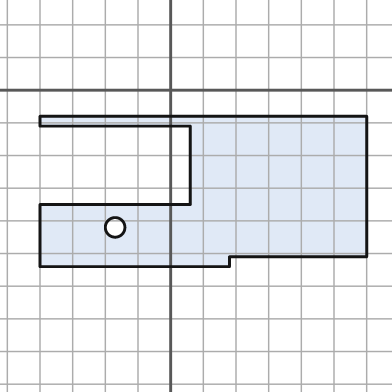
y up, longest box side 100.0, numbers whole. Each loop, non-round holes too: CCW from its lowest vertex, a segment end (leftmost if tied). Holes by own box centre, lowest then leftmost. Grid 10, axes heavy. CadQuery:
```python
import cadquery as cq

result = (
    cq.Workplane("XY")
    .moveTo(-40.0, -54.0)
    .lineTo(18.0, -54.0)
    .lineTo(18.0, -51.0)
    .lineTo(60.0, -51.0)
    .lineTo(60.0, -8.0)
    .lineTo(-40.0, -8.0)
    .lineTo(-40.0, -11.0)
    .lineTo(6.0, -11.0)
    .lineTo(6.0, -35.0)
    .lineTo(-40.0, -35.0)
    .close()
    .moveTo(-17.0, -42.0)
    .circle(3.0)
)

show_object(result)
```